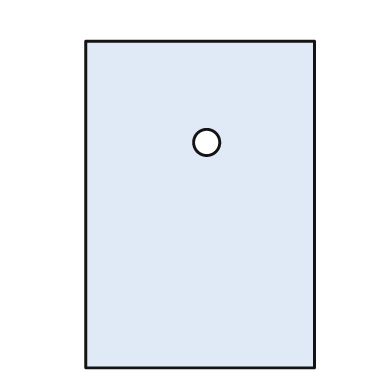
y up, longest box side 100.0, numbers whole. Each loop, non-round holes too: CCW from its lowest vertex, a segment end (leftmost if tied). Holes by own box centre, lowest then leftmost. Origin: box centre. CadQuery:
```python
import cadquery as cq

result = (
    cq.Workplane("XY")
    .moveTo(-35.0, -50.0)
    .lineTo(35.0, -50.0)
    .lineTo(35.0, 50.0)
    .lineTo(-35.0, 50.0)
    .close()
    .moveTo(2.0, 19.0)
    .circle(4.0)
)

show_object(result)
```